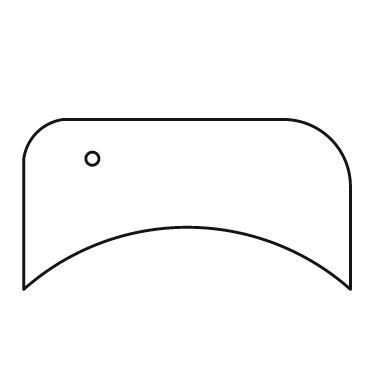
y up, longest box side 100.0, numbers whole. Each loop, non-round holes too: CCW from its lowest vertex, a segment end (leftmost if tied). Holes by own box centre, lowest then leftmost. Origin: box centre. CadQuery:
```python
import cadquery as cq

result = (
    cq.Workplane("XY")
    .moveTo(-50.0, -26.0)
    .threePointArc((0.0, -7.0), (50.0, -26.0))
    .lineTo(50.0, 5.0)
    .threePointArc((44.0, 20.0), (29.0, 26.0))
    .lineTo(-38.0, 26.0)
    .threePointArc((-46.0, 22.0), (-50.0, 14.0))
    .close()
    .moveTo(-29.0, 14.0)
    .circle(2.0)
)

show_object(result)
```